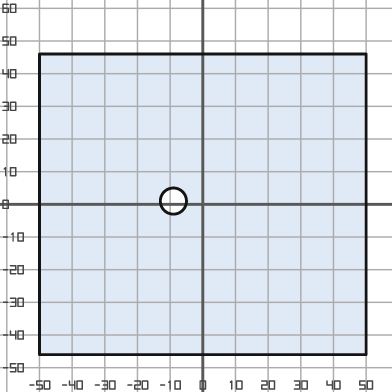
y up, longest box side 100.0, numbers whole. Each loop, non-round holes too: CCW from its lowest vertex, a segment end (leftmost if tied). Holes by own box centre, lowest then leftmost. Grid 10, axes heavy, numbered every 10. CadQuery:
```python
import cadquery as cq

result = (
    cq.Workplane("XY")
    .moveTo(-50.0, -46.0)
    .lineTo(50.0, -46.0)
    .lineTo(50.0, 46.0)
    .lineTo(-50.0, 46.0)
    .close()
    .moveTo(-9.0, 1.0)
    .circle(4.0)
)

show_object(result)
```